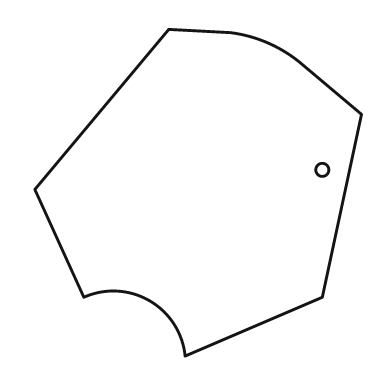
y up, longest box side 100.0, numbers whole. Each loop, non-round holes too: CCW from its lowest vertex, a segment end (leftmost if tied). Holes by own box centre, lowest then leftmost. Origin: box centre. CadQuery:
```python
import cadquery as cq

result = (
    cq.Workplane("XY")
    .moveTo(-4.0, -50.0)
    .lineTo(38.0, -32.0)
    .lineTo(50.0, 24.0)
    .lineTo(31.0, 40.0)
    .threePointArc((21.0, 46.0), (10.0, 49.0))
    .lineTo(-9.0, 50.0)
    .lineTo(-50.0, 1.0)
    .lineTo(-35.0, -32.0)
    .threePointArc((-15.0, -33.0), (-4.0, -50.0))
    .close()
    .moveTo(38.0, 7.0)
    .circle(2.0)
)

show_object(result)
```